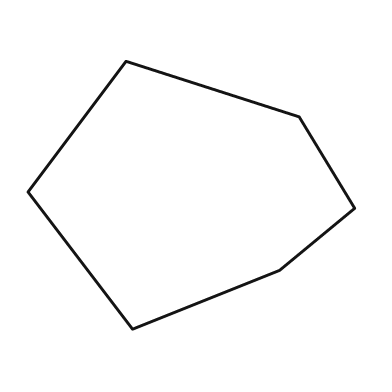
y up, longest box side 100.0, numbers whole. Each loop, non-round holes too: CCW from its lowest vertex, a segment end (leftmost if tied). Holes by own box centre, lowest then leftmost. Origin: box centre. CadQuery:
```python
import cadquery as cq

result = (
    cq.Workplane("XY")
    .moveTo(-18.0, -41.0)
    .lineTo(27.0, -23.0)
    .lineTo(50.0, -4.0)
    .lineTo(33.0, 24.0)
    .lineTo(-20.0, 41.0)
    .lineTo(-50.0, 1.0)
    .close()
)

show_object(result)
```